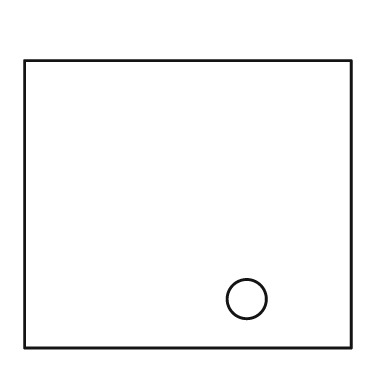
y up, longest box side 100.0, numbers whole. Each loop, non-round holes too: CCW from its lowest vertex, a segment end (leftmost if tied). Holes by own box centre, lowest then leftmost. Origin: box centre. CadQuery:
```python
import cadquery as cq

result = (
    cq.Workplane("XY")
    .moveTo(-50.0, -44.0)
    .lineTo(50.0, -44.0)
    .lineTo(50.0, 44.0)
    .lineTo(-50.0, 44.0)
    .close()
    .moveTo(18.0, -29.0)
    .circle(6.0)
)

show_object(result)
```